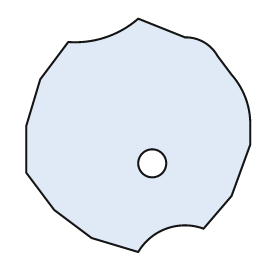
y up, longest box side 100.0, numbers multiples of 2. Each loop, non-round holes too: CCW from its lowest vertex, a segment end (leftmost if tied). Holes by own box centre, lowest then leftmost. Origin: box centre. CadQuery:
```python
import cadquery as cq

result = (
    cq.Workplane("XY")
    .moveTo(0.0, -50.0)
    .threePointArc((12.0, -40.0), (28.0, -40.0))
    .lineTo(40.0, -26.0)
    .lineTo(48.0, -4.0)
    .lineTo(48.0, 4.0)
    .threePointArc((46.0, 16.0), (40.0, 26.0))
    .lineTo(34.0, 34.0)
    .threePointArc((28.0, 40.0), (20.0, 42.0))
    .lineTo(0.0, 50.0)
    .threePointArc((-14.0, 42.0), (-30.0, 40.0))
    .lineTo(-42.0, 24.0)
    .lineTo(-48.0, 4.0)
    .lineTo(-48.0, -16.0)
    .lineTo(-36.0, -32.0)
    .lineTo(-20.0, -44.0)
    .close()
    .moveTo(6.0, -12.0)
    .circle(6.0)
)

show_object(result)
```